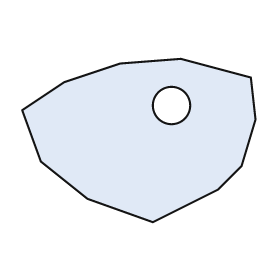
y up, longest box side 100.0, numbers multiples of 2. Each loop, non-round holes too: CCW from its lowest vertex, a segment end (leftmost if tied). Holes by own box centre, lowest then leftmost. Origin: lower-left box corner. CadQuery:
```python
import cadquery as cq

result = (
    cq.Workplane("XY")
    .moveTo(56.0, 0.0)
    .lineTo(84.0, 14.0)
    .lineTo(94.0, 24.0)
    .lineTo(100.0, 44.0)
    .lineTo(98.0, 62.0)
    .lineTo(68.0, 70.0)
    .lineTo(42.0, 68.0)
    .lineTo(18.0, 60.0)
    .lineTo(0.0, 48.0)
    .lineTo(8.0, 26.0)
    .lineTo(28.0, 10.0)
    .close()
    .moveTo(64.0, 50.0)
    .circle(8.0)
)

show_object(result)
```